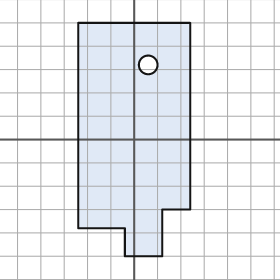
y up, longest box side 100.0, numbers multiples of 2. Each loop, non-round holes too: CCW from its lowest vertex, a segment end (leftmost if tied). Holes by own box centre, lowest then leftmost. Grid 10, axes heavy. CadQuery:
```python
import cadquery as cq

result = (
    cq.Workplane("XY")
    .moveTo(-4.0, -50.0)
    .lineTo(12.0, -50.0)
    .lineTo(12.0, -30.0)
    .lineTo(24.0, -30.0)
    .lineTo(24.0, 50.0)
    .lineTo(-24.0, 50.0)
    .lineTo(-24.0, -38.0)
    .lineTo(-4.0, -38.0)
    .close()
    .moveTo(6.0, 32.0)
    .circle(4.0)
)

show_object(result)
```